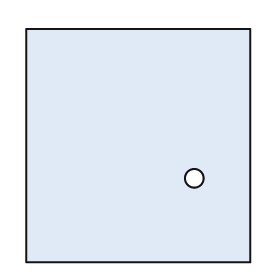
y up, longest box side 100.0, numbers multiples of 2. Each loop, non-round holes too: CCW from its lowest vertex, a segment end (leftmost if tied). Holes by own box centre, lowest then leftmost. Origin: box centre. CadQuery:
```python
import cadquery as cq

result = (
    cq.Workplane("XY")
    .moveTo(-48.0, -50.0)
    .lineTo(48.0, -50.0)
    .lineTo(48.0, 50.0)
    .lineTo(-48.0, 50.0)
    .close()
    .moveTo(24.0, -14.0)
    .circle(4.0)
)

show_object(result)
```